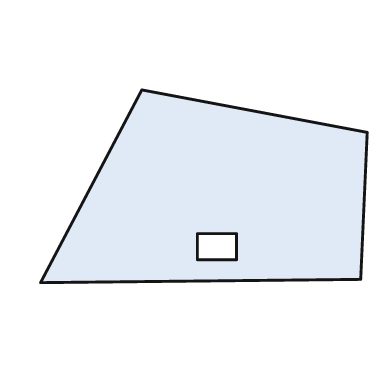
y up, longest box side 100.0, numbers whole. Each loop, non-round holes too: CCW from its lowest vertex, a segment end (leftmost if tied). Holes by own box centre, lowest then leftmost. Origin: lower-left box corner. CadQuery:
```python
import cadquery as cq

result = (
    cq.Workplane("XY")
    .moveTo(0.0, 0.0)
    .lineTo(98.0, 1.0)
    .lineTo(100.0, 46.0)
    .lineTo(31.0, 59.0)
    .close()
    .moveTo(48.0, 7.0)
    .lineTo(60.0, 7.0)
    .lineTo(60.0, 15.0)
    .lineTo(48.0, 15.0)
    .close()
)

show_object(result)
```